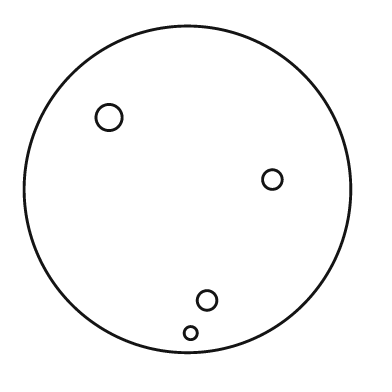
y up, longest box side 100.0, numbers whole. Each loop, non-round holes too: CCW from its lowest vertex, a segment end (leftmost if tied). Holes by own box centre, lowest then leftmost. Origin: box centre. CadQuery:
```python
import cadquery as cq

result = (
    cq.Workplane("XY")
    .moveTo(0.0, 0.0)
    .circle(50.0)
    .moveTo(1.0, -44.0)
    .circle(2.0)
    .moveTo(6.0, -34.0)
    .circle(3.0)
    .moveTo(26.0, 3.0)
    .circle(3.0)
    .moveTo(-24.0, 22.0)
    .circle(4.0)
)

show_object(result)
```